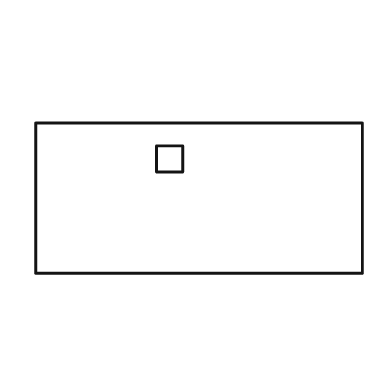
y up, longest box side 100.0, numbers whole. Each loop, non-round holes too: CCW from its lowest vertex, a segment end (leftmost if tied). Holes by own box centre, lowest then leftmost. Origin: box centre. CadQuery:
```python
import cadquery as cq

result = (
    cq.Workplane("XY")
    .moveTo(-50.0, -23.0)
    .lineTo(50.0, -23.0)
    .lineTo(50.0, 23.0)
    .lineTo(-50.0, 23.0)
    .close()
    .moveTo(-13.0, 8.0)
    .lineTo(-5.0, 8.0)
    .lineTo(-5.0, 16.0)
    .lineTo(-13.0, 16.0)
    .close()
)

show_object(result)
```